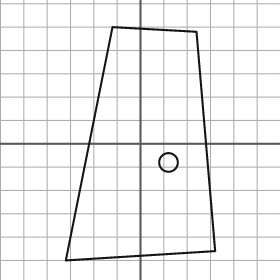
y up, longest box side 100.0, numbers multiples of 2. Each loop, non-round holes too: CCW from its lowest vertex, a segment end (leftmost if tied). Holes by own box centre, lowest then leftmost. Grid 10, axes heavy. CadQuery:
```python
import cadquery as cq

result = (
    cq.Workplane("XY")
    .moveTo(-32.0, -50.0)
    .lineTo(32.0, -46.0)
    .lineTo(24.0, 48.0)
    .lineTo(-12.0, 50.0)
    .close()
    .moveTo(12.0, -8.0)
    .circle(4.0)
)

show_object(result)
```